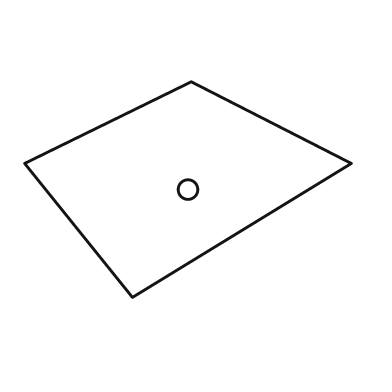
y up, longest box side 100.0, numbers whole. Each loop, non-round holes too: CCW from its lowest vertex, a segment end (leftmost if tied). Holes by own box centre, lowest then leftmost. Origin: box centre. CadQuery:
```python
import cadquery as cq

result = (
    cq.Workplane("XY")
    .moveTo(-17.0, -33.0)
    .lineTo(50.0, 8.0)
    .lineTo(1.0, 33.0)
    .lineTo(-50.0, 8.0)
    .close()
    .moveTo(0.0, 0.0)
    .circle(3.0)
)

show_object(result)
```